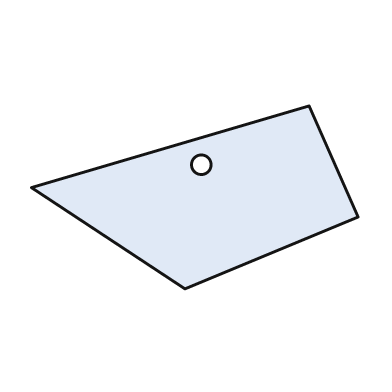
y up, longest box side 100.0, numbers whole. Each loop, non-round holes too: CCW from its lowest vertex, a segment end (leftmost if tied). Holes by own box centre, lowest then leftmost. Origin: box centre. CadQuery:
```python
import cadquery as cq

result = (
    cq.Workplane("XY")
    .moveTo(-3.0, -28.0)
    .lineTo(50.0, -6.0)
    .lineTo(35.0, 28.0)
    .lineTo(-50.0, 3.0)
    .close()
    .moveTo(2.0, 10.0)
    .circle(3.0)
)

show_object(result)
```